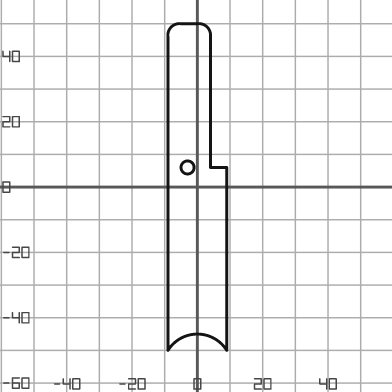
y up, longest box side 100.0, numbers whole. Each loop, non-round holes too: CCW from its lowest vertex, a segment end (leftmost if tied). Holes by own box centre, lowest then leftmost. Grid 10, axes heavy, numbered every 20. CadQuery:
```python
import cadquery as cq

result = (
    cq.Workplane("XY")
    .moveTo(-9.0, -50.0)
    .threePointArc((0.0, -45.0), (9.0, -50.0))
    .lineTo(9.0, 6.0)
    .lineTo(4.0, 6.0)
    .lineTo(4.0, 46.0)
    .threePointArc((3.0, 49.0), (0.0, 50.0))
    .lineTo(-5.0, 50.0)
    .threePointArc((-8.0, 49.0), (-9.0, 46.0))
    .close()
    .moveTo(-3.0, 6.0)
    .circle(2.0)
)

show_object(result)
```